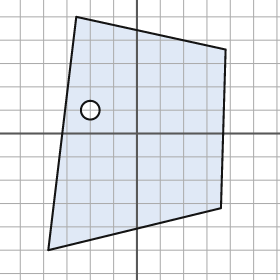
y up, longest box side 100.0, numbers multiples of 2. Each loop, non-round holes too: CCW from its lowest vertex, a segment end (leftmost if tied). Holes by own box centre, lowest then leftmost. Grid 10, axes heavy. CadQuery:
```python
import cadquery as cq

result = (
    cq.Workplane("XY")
    .moveTo(-38.0, -50.0)
    .lineTo(36.0, -32.0)
    .lineTo(38.0, 36.0)
    .lineTo(-26.0, 50.0)
    .close()
    .moveTo(-20.0, 10.0)
    .circle(4.0)
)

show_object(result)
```